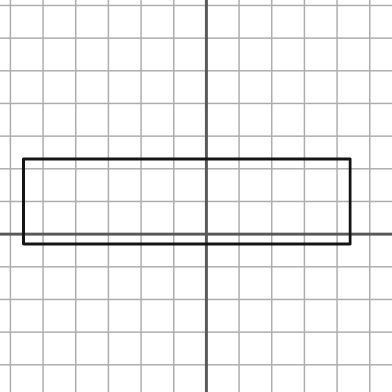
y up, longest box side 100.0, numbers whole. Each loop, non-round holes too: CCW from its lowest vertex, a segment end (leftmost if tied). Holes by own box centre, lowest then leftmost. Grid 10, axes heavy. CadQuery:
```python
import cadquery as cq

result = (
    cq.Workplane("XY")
    .moveTo(-56.0, -3.0)
    .lineTo(44.0, -3.0)
    .lineTo(44.0, 23.0)
    .lineTo(-56.0, 23.0)
    .close()
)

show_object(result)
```